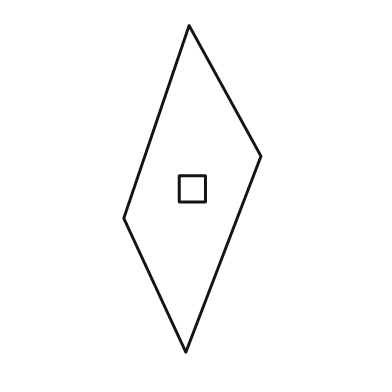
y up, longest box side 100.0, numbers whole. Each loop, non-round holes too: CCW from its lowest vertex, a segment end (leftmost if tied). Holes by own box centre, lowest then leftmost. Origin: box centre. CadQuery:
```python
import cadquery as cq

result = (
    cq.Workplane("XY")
    .moveTo(-2.0, -50.0)
    .lineTo(21.0, 10.0)
    .lineTo(-1.0, 50.0)
    .lineTo(-21.0, -9.0)
    .close()
    .moveTo(-4.0, -4.0)
    .lineTo(4.0, -4.0)
    .lineTo(4.0, 4.0)
    .lineTo(-4.0, 4.0)
    .close()
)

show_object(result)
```